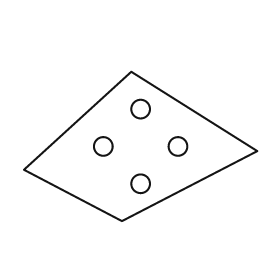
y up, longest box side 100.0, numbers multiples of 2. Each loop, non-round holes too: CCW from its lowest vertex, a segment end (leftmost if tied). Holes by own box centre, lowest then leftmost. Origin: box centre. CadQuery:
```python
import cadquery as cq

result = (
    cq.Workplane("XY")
    .moveTo(-8.0, -32.0)
    .lineTo(50.0, -2.0)
    .lineTo(-4.0, 32.0)
    .lineTo(-50.0, -10.0)
    .close()
    .moveTo(0.0, -16.0)
    .circle(4.0)
    .moveTo(-16.0, 0.0)
    .circle(4.0)
    .moveTo(16.0, 0.0)
    .circle(4.0)
    .moveTo(0.0, 16.0)
    .circle(4.0)
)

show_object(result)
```